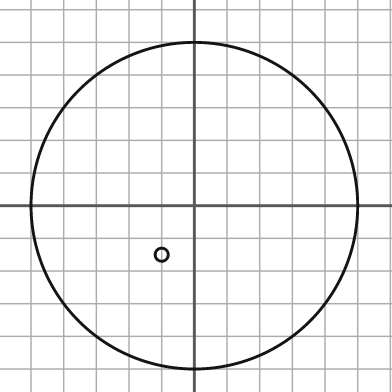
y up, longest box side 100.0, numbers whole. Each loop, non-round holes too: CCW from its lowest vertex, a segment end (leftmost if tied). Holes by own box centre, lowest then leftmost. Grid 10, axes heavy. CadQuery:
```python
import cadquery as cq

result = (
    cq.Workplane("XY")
    .moveTo(0.0, 0.0)
    .circle(50.0)
    .moveTo(-10.0, -15.0)
    .circle(2.0)
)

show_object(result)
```